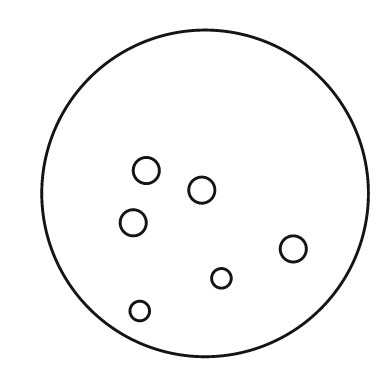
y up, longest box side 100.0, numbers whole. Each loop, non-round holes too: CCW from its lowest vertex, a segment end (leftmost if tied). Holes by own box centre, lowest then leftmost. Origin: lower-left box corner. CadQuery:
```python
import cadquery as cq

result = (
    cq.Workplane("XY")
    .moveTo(50.0, 50.0)
    .circle(50.0)
    .moveTo(30.0, 14.0)
    .circle(3.0)
    .moveTo(55.0, 24.0)
    .circle(3.0)
    .moveTo(77.0, 33.0)
    .circle(4.0)
    .moveTo(28.0, 41.0)
    .circle(4.0)
    .moveTo(49.0, 51.0)
    .circle(4.0)
    .moveTo(32.0, 57.0)
    .circle(4.0)
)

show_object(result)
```